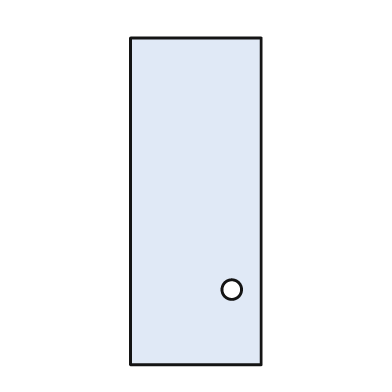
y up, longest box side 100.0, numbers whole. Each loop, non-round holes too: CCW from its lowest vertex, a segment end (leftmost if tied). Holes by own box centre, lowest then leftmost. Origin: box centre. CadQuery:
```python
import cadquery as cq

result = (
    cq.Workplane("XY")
    .moveTo(-20.0, -50.0)
    .lineTo(20.0, -50.0)
    .lineTo(20.0, 50.0)
    .lineTo(-20.0, 50.0)
    .close()
    .moveTo(11.0, -27.0)
    .circle(3.0)
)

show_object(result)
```